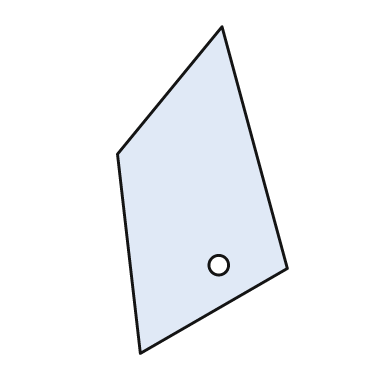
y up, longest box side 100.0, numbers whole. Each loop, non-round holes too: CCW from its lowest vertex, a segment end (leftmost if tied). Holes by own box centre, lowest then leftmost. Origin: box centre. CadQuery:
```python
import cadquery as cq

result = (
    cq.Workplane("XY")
    .moveTo(-19.0, -50.0)
    .lineTo(26.0, -24.0)
    .lineTo(6.0, 50.0)
    .lineTo(-26.0, 11.0)
    .close()
    .moveTo(5.0, -23.0)
    .circle(3.0)
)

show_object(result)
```